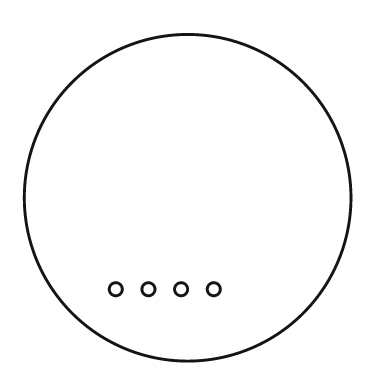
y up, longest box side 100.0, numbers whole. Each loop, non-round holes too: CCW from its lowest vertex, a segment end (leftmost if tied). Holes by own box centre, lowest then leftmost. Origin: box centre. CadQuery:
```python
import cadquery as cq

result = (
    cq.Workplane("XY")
    .moveTo(0.0, 0.0)
    .circle(50.0)
    .moveTo(-22.0, -28.0)
    .circle(2.0)
    .moveTo(-12.0, -28.0)
    .circle(2.0)
    .moveTo(-2.0, -28.0)
    .circle(2.0)
    .moveTo(8.0, -28.0)
    .circle(2.0)
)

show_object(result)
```